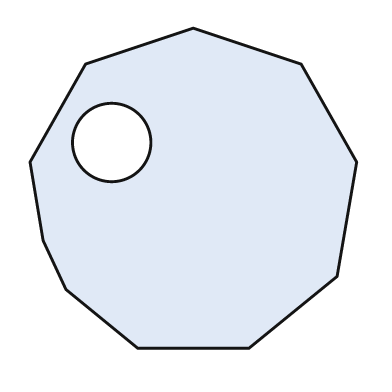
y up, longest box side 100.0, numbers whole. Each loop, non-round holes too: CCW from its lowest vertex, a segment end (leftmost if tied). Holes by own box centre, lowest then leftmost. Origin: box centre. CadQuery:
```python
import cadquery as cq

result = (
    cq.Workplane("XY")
    .moveTo(-17.0, -49.0)
    .lineTo(17.0, -49.0)
    .lineTo(44.0, -27.0)
    .lineTo(50.0, 8.0)
    .lineTo(33.0, 38.0)
    .lineTo(0.0, 49.0)
    .lineTo(-33.0, 38.0)
    .lineTo(-50.0, 8.0)
    .lineTo(-46.0, -16.0)
    .lineTo(-39.0, -31.0)
    .close()
    .moveTo(-25.0, 14.0)
    .circle(12.0)
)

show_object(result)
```